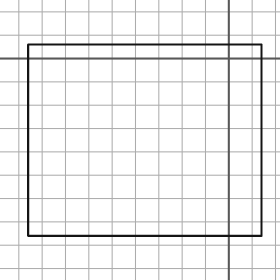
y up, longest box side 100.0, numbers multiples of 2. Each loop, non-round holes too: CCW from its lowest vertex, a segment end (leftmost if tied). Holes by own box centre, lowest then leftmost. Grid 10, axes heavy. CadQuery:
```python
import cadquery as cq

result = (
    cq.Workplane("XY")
    .moveTo(-86.0, -76.0)
    .lineTo(14.0, -76.0)
    .lineTo(14.0, 6.0)
    .lineTo(-86.0, 6.0)
    .close()
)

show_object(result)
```